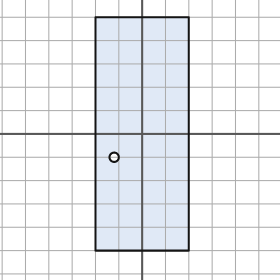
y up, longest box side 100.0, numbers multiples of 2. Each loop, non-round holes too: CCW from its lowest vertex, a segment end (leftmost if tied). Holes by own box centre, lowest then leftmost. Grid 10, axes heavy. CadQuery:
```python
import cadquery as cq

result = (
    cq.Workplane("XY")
    .moveTo(-20.0, -50.0)
    .lineTo(20.0, -50.0)
    .lineTo(20.0, 50.0)
    .lineTo(-20.0, 50.0)
    .close()
    .moveTo(-12.0, -10.0)
    .circle(2.0)
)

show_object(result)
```